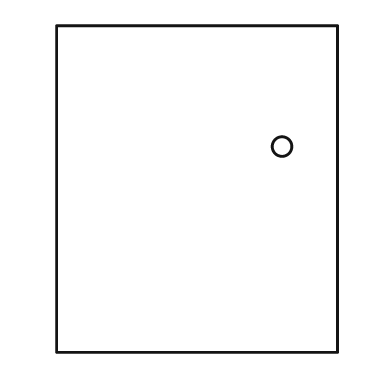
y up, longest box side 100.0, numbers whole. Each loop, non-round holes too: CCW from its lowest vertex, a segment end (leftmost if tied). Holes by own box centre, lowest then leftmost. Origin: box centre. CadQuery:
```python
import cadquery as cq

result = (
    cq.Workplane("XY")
    .moveTo(-43.0, -50.0)
    .lineTo(43.0, -50.0)
    .lineTo(43.0, 50.0)
    .lineTo(-43.0, 50.0)
    .close()
    .moveTo(26.0, 13.0)
    .circle(3.0)
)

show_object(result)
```